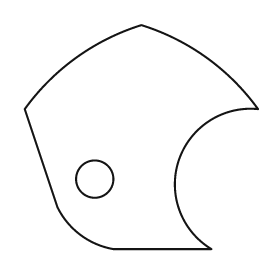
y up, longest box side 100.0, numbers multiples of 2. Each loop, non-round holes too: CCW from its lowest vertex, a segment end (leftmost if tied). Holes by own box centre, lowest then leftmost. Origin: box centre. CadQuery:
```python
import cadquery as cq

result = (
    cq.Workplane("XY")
    .moveTo(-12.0, -48.0)
    .lineTo(30.0, -48.0)
    .threePointArc((16.0, -10.0), (50.0, 12.0))
    .threePointArc((28.0, 34.0), (0.0, 48.0))
    .threePointArc((-28.0, 34.0), (-50.0, 12.0))
    .lineTo(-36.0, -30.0)
    .threePointArc((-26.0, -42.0), (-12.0, -48.0))
    .close()
    .moveTo(-20.0, -18.0)
    .circle(8.0)
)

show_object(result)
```